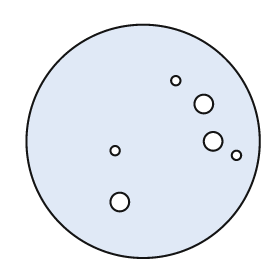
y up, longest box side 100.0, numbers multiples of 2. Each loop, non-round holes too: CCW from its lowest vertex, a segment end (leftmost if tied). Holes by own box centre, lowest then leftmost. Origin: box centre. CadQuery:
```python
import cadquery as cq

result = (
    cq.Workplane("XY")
    .moveTo(0.0, 0.0)
    .circle(50.0)
    .moveTo(-10.0, -26.0)
    .circle(4.0)
    .moveTo(40.0, -6.0)
    .circle(2.0)
    .moveTo(-12.0, -4.0)
    .circle(2.0)
    .moveTo(30.0, 0.0)
    .circle(4.0)
    .moveTo(26.0, 16.0)
    .circle(4.0)
    .moveTo(14.0, 26.0)
    .circle(2.0)
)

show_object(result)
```